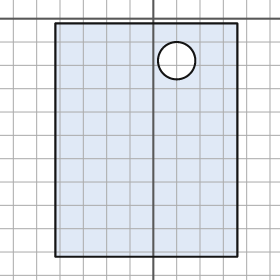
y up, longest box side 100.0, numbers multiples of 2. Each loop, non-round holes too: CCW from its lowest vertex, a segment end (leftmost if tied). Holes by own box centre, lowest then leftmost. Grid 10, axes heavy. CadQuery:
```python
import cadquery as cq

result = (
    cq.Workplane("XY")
    .moveTo(-42.0, -102.0)
    .lineTo(36.0, -102.0)
    .lineTo(36.0, -2.0)
    .lineTo(-42.0, -2.0)
    .close()
    .moveTo(10.0, -18.0)
    .circle(8.0)
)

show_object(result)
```